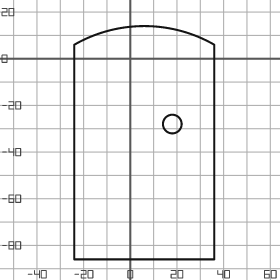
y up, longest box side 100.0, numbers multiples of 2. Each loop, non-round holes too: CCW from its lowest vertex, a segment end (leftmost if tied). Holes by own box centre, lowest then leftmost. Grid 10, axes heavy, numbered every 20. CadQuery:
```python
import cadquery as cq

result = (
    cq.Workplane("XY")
    .moveTo(-24.0, -86.0)
    .lineTo(36.0, -86.0)
    .lineTo(36.0, 6.0)
    .threePointArc((6.0, 14.0), (-24.0, 6.0))
    .close()
    .moveTo(18.0, -28.0)
    .circle(4.0)
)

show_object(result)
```